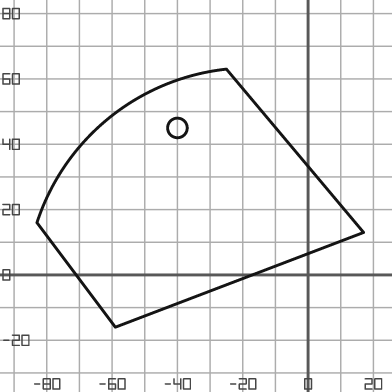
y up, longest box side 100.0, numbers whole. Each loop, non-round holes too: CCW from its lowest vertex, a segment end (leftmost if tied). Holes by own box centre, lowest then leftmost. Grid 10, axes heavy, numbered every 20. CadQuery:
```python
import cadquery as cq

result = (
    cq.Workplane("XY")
    .moveTo(-59.0, -16.0)
    .lineTo(17.0, 13.0)
    .lineTo(-25.0, 63.0)
    .threePointArc((-61.0, 48.0), (-83.0, 16.0))
    .close()
    .moveTo(-40.0, 45.0)
    .circle(3.0)
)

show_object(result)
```